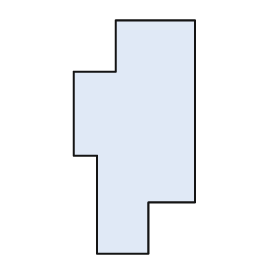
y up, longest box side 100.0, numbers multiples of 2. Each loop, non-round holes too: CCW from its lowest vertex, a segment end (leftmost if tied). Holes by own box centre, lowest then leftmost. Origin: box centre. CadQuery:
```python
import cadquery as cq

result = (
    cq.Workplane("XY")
    .moveTo(-16.0, -50.0)
    .lineTo(6.0, -50.0)
    .lineTo(6.0, -28.0)
    .lineTo(26.0, -28.0)
    .lineTo(26.0, 50.0)
    .lineTo(-8.0, 50.0)
    .lineTo(-8.0, 28.0)
    .lineTo(-26.0, 28.0)
    .lineTo(-26.0, -8.0)
    .lineTo(-16.0, -8.0)
    .close()
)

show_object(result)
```